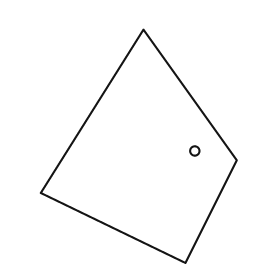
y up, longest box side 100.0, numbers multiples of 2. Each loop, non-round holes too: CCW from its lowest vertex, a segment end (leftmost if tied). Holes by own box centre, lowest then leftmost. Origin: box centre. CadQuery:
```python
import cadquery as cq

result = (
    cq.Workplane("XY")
    .moveTo(20.0, -50.0)
    .lineTo(42.0, -6.0)
    .lineTo(2.0, 50.0)
    .lineTo(-42.0, -20.0)
    .close()
    .moveTo(24.0, -2.0)
    .circle(2.0)
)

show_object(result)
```